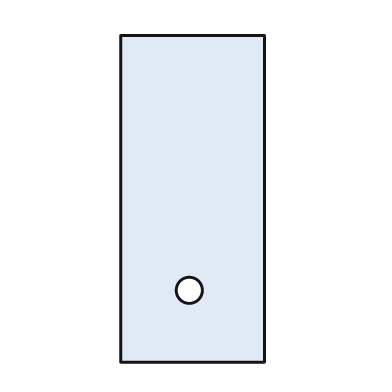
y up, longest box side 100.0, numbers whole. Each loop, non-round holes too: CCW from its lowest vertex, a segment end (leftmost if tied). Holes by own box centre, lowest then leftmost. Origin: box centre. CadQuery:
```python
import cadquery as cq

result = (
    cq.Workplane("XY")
    .moveTo(-22.0, -50.0)
    .lineTo(22.0, -50.0)
    .lineTo(22.0, 50.0)
    .lineTo(-22.0, 50.0)
    .close()
    .moveTo(-1.0, -28.0)
    .circle(4.0)
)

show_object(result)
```